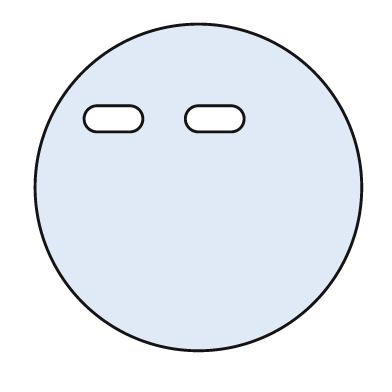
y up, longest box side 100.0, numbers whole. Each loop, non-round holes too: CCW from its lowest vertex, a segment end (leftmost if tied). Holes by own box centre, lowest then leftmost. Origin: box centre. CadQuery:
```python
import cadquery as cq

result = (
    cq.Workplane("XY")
    .moveTo(0.0, 0.0)
    .circle(50.0)
    .moveTo(-31.0, 17.0)
    .lineTo(-21.0, 17.0)
    .threePointArc((-17.0, 21.0), (-21.0, 25.0))
    .lineTo(-31.0, 25.0)
    .threePointArc((-35.0, 21.0), (-31.0, 17.0))
    .close()
    .moveTo(0.0, 17.0)
    .lineTo(10.0, 17.0)
    .threePointArc((14.0, 21.0), (10.0, 25.0))
    .lineTo(0.0, 25.0)
    .threePointArc((-4.0, 21.0), (0.0, 17.0))
    .close()
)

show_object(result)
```